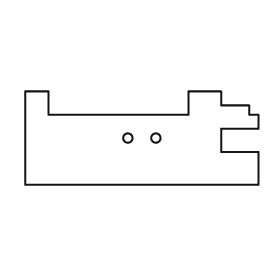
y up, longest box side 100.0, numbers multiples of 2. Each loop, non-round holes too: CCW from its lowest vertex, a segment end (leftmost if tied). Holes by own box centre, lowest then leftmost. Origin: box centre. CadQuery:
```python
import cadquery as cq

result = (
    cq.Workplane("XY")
    .moveTo(-50.0, -20.0)
    .lineTo(50.0, -20.0)
    .lineTo(50.0, -6.0)
    .lineTo(34.0, -6.0)
    .lineTo(34.0, 4.0)
    .lineTo(50.0, 4.0)
    .lineTo(50.0, 10.0)
    .lineTo(46.0, 10.0)
    .lineTo(46.0, 14.0)
    .lineTo(34.0, 14.0)
    .lineTo(34.0, 20.0)
    .lineTo(20.0, 20.0)
    .lineTo(20.0, 10.0)
    .lineTo(-40.0, 10.0)
    .lineTo(-40.0, 20.0)
    .lineTo(-50.0, 20.0)
    .close()
    .moveTo(-6.0, 0.0)
    .circle(2.0)
    .moveTo(6.0, 0.0)
    .circle(2.0)
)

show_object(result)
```